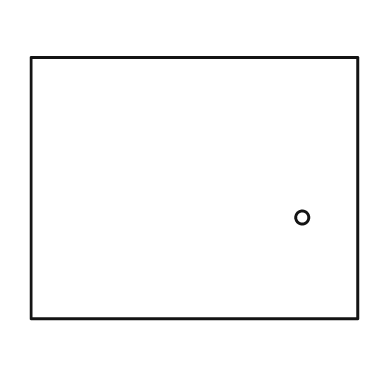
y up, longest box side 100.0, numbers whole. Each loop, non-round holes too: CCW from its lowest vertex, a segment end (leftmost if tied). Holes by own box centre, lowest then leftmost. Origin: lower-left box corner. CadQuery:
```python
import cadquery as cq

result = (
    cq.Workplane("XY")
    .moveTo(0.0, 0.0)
    .lineTo(100.0, 0.0)
    .lineTo(100.0, 80.0)
    .lineTo(0.0, 80.0)
    .close()
    .moveTo(83.0, 31.0)
    .circle(2.0)
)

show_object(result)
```